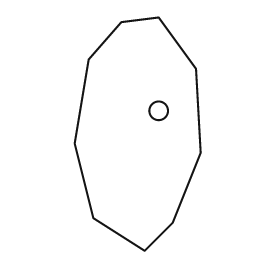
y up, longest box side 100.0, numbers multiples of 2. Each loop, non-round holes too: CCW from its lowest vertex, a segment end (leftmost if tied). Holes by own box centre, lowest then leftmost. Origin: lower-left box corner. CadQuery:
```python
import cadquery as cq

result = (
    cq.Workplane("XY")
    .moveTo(30.0, 0.0)
    .lineTo(42.0, 12.0)
    .lineTo(54.0, 42.0)
    .lineTo(52.0, 78.0)
    .lineTo(36.0, 100.0)
    .lineTo(20.0, 98.0)
    .lineTo(6.0, 82.0)
    .lineTo(0.0, 46.0)
    .lineTo(8.0, 14.0)
    .close()
    .moveTo(36.0, 60.0)
    .circle(4.0)
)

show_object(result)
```